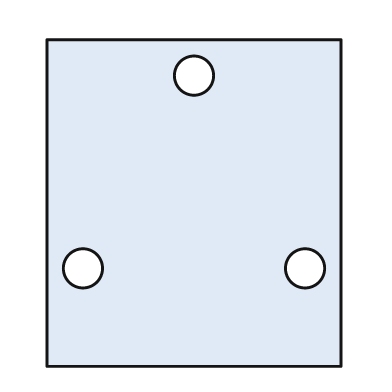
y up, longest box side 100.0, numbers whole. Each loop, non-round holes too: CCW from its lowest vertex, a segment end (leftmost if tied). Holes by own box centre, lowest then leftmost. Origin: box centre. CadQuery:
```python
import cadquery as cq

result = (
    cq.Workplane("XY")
    .moveTo(-45.0, -50.0)
    .lineTo(45.0, -50.0)
    .lineTo(45.0, 50.0)
    .lineTo(-45.0, 50.0)
    .close()
    .moveTo(-34.0, -20.0)
    .circle(6.0)
    .moveTo(34.0, -20.0)
    .circle(6.0)
    .moveTo(0.0, 39.0)
    .circle(6.0)
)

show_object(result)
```